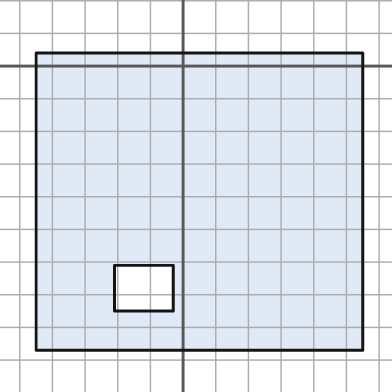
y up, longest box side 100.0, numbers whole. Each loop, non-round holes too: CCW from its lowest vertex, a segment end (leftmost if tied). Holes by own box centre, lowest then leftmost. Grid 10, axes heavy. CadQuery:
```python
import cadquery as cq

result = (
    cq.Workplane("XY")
    .moveTo(-45.0, -87.0)
    .lineTo(55.0, -87.0)
    .lineTo(55.0, 4.0)
    .lineTo(-45.0, 4.0)
    .close()
    .moveTo(-21.0, -75.0)
    .lineTo(-3.0, -75.0)
    .lineTo(-3.0, -61.0)
    .lineTo(-21.0, -61.0)
    .close()
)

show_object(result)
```